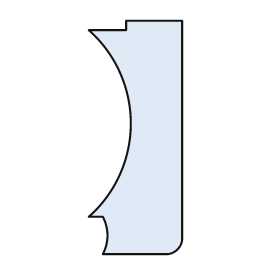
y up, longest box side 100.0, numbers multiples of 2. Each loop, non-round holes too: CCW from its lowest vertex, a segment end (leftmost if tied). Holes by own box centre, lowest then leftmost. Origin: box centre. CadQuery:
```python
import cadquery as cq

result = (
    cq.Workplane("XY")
    .moveTo(-14.0, -50.0)
    .lineTo(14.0, -50.0)
    .threePointArc((18.0, -48.0), (20.0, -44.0))
    .lineTo(20.0, 50.0)
    .lineTo(-4.0, 50.0)
    .lineTo(-4.0, 46.0)
    .lineTo(-20.0, 46.0)
    .threePointArc((-2.0, 6.0), (-20.0, -34.0))
    .lineTo(-14.0, -34.0)
    .threePointArc((-12.0, -42.0), (-14.0, -50.0))
    .close()
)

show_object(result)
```